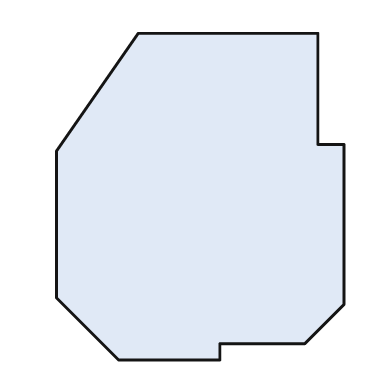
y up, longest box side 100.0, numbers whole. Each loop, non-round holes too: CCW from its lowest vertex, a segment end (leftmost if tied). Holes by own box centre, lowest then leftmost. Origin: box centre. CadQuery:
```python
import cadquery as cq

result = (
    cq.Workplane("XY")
    .moveTo(-25.0, -50.0)
    .lineTo(6.0, -50.0)
    .lineTo(6.0, -45.0)
    .lineTo(32.0, -45.0)
    .lineTo(44.0, -33.0)
    .lineTo(44.0, 16.0)
    .lineTo(36.0, 16.0)
    .lineTo(36.0, 50.0)
    .lineTo(-19.0, 50.0)
    .lineTo(-44.0, 14.0)
    .lineTo(-44.0, -31.0)
    .close()
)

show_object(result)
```